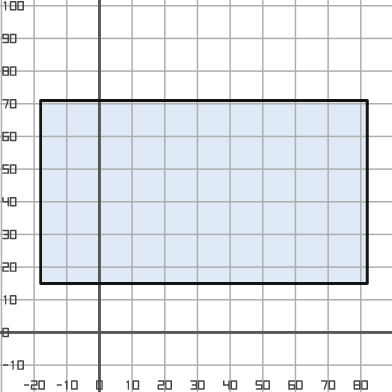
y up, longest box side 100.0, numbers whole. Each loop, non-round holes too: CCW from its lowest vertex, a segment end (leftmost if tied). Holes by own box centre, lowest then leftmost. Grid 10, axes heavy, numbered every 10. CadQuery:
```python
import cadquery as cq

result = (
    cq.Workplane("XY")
    .moveTo(-18.0, 15.0)
    .lineTo(82.0, 15.0)
    .lineTo(82.0, 71.0)
    .lineTo(-18.0, 71.0)
    .close()
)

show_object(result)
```